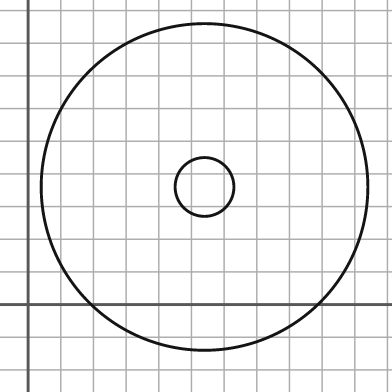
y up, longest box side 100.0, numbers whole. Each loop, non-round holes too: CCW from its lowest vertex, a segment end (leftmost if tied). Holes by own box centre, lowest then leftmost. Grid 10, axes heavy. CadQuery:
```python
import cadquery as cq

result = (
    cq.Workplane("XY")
    .moveTo(54.0, 36.0)
    .circle(50.0)
    .moveTo(54.0, 36.0)
    .circle(9.0)
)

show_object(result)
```